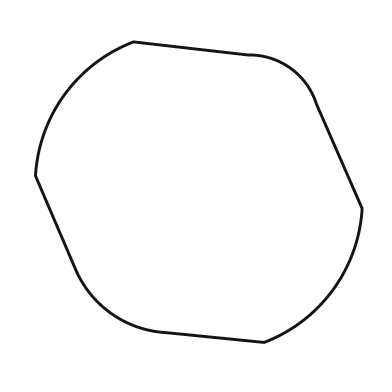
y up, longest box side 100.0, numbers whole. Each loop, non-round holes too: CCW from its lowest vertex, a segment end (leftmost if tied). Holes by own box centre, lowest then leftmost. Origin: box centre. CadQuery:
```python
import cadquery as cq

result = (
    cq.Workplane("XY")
    .moveTo(20.0, -46.0)
    .threePointArc((41.0, -30.0), (50.0, -5.0))
    .lineTo(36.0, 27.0)
    .threePointArc((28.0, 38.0), (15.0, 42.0))
    .lineTo(-20.0, 46.0)
    .threePointArc((-41.0, 30.0), (-50.0, 5.0))
    .lineTo(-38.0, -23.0)
    .threePointArc((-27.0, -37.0), (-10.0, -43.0))
    .close()
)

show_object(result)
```